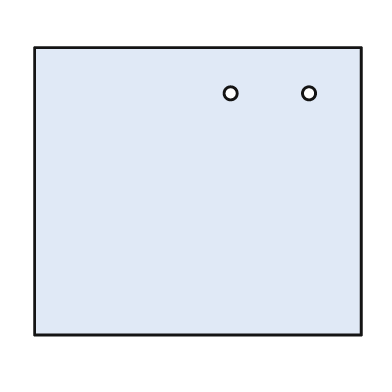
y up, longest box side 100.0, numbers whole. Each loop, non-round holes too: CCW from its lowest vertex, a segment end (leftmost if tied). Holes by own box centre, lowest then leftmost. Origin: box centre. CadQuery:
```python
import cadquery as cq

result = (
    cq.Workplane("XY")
    .moveTo(-50.0, -44.0)
    .lineTo(50.0, -44.0)
    .lineTo(50.0, 44.0)
    .lineTo(-50.0, 44.0)
    .close()
    .moveTo(10.0, 30.0)
    .circle(2.0)
    .moveTo(34.0, 30.0)
    .circle(2.0)
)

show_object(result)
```